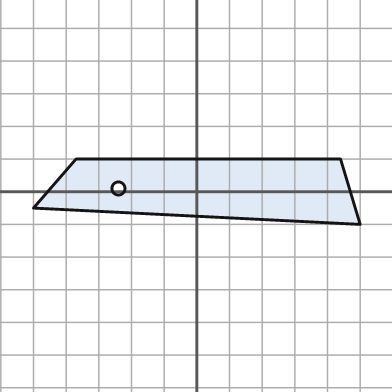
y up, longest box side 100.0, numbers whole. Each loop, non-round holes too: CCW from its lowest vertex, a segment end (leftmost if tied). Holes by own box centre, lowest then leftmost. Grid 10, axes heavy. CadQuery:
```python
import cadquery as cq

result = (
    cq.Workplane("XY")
    .moveTo(50.0, -10.0)
    .lineTo(44.0, 10.0)
    .lineTo(-37.0, 10.0)
    .lineTo(-50.0, -5.0)
    .close()
    .moveTo(-24.0, 1.0)
    .circle(2.0)
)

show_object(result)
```